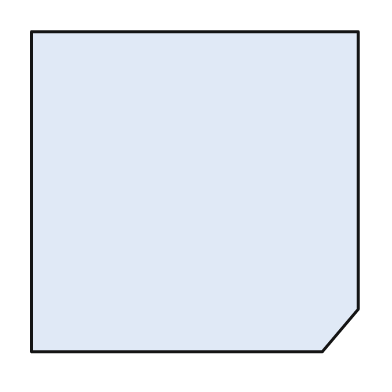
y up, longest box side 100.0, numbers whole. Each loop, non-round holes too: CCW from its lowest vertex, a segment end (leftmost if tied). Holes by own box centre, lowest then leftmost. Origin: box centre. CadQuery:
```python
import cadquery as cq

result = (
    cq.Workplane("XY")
    .moveTo(-50.0, -49.0)
    .lineTo(39.0, -49.0)
    .lineTo(50.0, -36.0)
    .lineTo(50.0, 49.0)
    .lineTo(-50.0, 49.0)
    .close()
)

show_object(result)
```